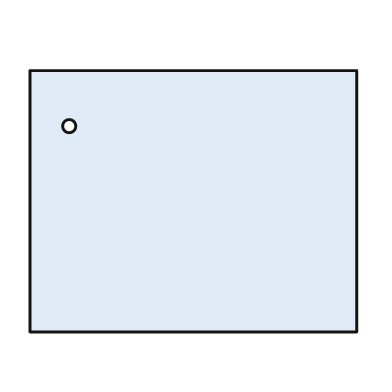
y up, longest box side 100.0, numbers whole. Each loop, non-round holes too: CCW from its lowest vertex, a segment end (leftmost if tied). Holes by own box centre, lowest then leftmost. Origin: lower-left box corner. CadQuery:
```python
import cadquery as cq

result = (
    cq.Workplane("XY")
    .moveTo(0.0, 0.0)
    .lineTo(100.0, 0.0)
    .lineTo(100.0, 80.0)
    .lineTo(0.0, 80.0)
    .close()
    .moveTo(12.0, 63.0)
    .circle(2.0)
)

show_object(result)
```